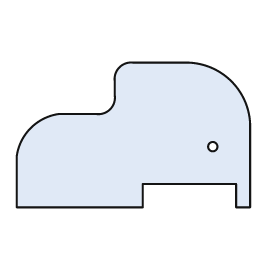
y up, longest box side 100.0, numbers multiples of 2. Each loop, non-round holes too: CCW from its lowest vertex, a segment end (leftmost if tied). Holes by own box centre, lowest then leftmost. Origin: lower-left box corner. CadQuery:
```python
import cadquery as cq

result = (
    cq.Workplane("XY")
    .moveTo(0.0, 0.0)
    .lineTo(54.0, 0.0)
    .lineTo(54.0, 10.0)
    .lineTo(94.0, 10.0)
    .lineTo(94.0, 0.0)
    .lineTo(100.0, 0.0)
    .lineTo(100.0, 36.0)
    .threePointArc((92.0, 54.0), (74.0, 62.0))
    .lineTo(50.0, 62.0)
    .threePointArc((44.0, 60.0), (42.0, 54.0))
    .lineTo(42.0, 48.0)
    .threePointArc((40.0, 42.0), (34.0, 40.0))
    .lineTo(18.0, 40.0)
    .threePointArc((6.0, 34.0), (0.0, 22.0))
    .close()
    .moveTo(84.0, 26.0)
    .circle(2.0)
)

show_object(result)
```